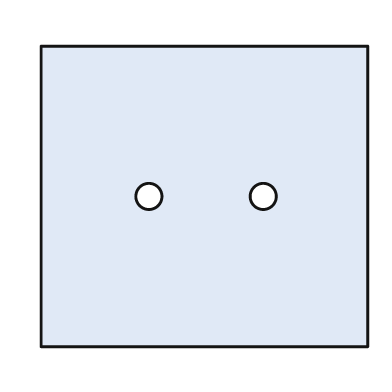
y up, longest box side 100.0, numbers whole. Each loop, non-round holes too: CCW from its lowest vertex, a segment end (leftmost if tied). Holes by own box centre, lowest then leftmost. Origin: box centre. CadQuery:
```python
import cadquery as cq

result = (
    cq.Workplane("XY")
    .moveTo(-50.0, -46.0)
    .lineTo(50.0, -46.0)
    .lineTo(50.0, 46.0)
    .lineTo(-50.0, 46.0)
    .close()
    .moveTo(-17.0, 0.0)
    .circle(4.0)
    .moveTo(18.0, 0.0)
    .circle(4.0)
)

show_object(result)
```